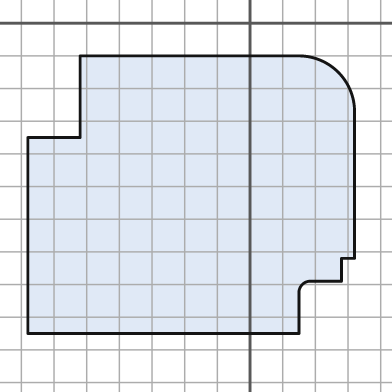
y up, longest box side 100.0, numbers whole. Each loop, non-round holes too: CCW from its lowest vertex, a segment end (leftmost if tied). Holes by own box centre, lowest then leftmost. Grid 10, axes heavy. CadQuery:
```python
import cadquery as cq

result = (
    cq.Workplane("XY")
    .moveTo(-68.0, -95.0)
    .lineTo(15.0, -95.0)
    .lineTo(15.0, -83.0)
    .threePointArc((16.0, -80.0), (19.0, -79.0))
    .lineTo(28.0, -79.0)
    .lineTo(28.0, -72.0)
    .lineTo(32.0, -72.0)
    .lineTo(32.0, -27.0)
    .threePointArc((27.0, -15.0), (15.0, -10.0))
    .lineTo(-52.0, -10.0)
    .lineTo(-52.0, -35.0)
    .lineTo(-68.0, -35.0)
    .close()
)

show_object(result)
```